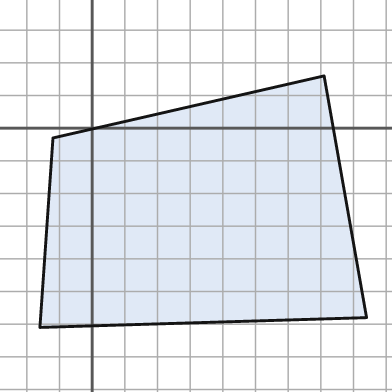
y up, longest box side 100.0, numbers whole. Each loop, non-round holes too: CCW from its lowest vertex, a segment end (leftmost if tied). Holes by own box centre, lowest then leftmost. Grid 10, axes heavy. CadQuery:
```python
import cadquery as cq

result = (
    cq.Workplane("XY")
    .moveTo(-16.0, -61.0)
    .lineTo(84.0, -58.0)
    .lineTo(71.0, 16.0)
    .lineTo(-12.0, -3.0)
    .close()
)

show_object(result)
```